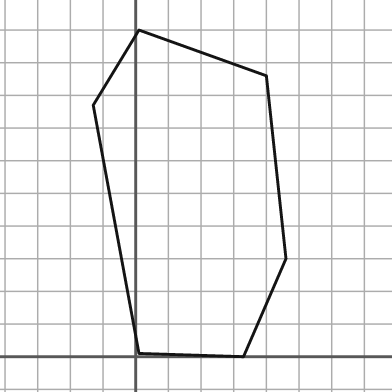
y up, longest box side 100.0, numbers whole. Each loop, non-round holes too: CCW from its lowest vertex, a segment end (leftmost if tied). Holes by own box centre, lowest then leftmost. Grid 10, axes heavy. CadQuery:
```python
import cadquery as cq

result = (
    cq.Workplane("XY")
    .moveTo(33.0, 0.0)
    .lineTo(46.0, 30.0)
    .lineTo(40.0, 86.0)
    .lineTo(1.0, 100.0)
    .lineTo(-13.0, 77.0)
    .lineTo(1.0, 1.0)
    .close()
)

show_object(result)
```